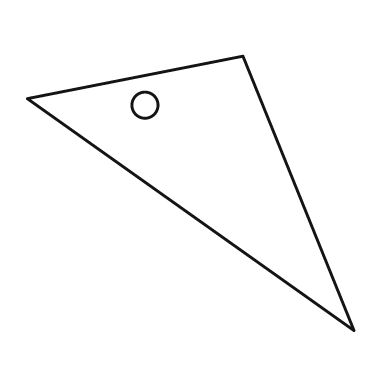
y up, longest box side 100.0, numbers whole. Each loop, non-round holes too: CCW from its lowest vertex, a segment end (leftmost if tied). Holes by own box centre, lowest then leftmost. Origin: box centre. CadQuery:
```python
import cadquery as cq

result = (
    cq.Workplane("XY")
    .moveTo(50.0, -42.0)
    .lineTo(16.0, 42.0)
    .lineTo(-50.0, 29.0)
    .close()
    .moveTo(-14.0, 27.0)
    .circle(4.0)
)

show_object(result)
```